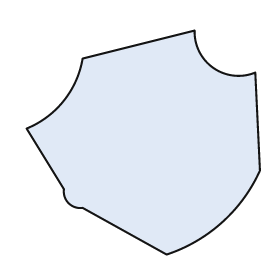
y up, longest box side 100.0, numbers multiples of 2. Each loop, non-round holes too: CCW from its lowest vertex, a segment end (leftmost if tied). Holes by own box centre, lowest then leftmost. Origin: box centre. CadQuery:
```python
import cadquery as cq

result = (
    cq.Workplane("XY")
    .moveTo(10.0, -48.0)
    .threePointArc((34.0, -34.0), (50.0, -12.0))
    .lineTo(48.0, 30.0)
    .threePointArc((30.0, 32.0), (22.0, 48.0))
    .lineTo(-26.0, 36.0)
    .threePointArc((-34.0, 18.0), (-50.0, 6.0))
    .lineTo(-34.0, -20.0)
    .threePointArc((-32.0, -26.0), (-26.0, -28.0))
    .close()
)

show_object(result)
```